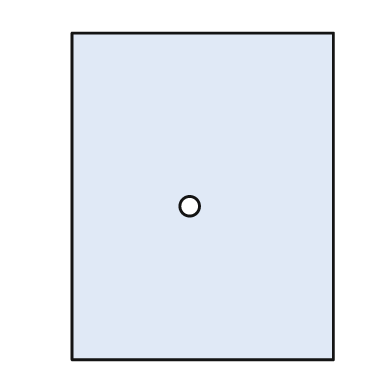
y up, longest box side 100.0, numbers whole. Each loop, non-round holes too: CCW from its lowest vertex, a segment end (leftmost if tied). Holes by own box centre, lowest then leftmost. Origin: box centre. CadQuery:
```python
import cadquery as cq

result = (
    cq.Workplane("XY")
    .moveTo(-40.0, -50.0)
    .lineTo(40.0, -50.0)
    .lineTo(40.0, 50.0)
    .lineTo(-40.0, 50.0)
    .close()
    .moveTo(-4.0, -3.0)
    .circle(3.0)
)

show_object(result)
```